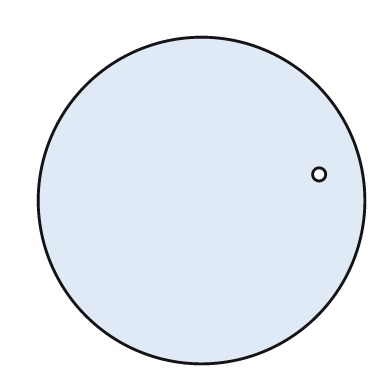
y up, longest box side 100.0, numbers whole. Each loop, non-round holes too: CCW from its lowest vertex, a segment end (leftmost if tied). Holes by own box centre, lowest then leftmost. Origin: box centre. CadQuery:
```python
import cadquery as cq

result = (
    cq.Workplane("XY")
    .moveTo(0.0, 0.0)
    .circle(50.0)
    .moveTo(36.0, 8.0)
    .circle(2.0)
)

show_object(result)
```